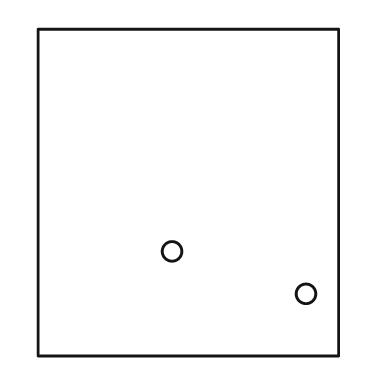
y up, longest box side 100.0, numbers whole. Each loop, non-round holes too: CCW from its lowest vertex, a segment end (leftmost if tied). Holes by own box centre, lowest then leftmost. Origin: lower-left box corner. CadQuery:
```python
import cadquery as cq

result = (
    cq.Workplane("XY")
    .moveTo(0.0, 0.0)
    .lineTo(92.0, 0.0)
    .lineTo(92.0, 100.0)
    .lineTo(0.0, 100.0)
    .close()
    .moveTo(82.0, 19.0)
    .circle(3.0)
    .moveTo(41.0, 32.0)
    .circle(3.0)
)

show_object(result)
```